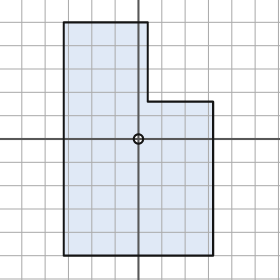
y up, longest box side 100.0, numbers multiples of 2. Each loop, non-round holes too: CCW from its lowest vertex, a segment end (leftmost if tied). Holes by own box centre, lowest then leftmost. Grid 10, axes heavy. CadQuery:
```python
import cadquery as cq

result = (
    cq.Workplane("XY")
    .moveTo(-32.0, -50.0)
    .lineTo(32.0, -50.0)
    .lineTo(32.0, 16.0)
    .lineTo(4.0, 16.0)
    .lineTo(4.0, 50.0)
    .lineTo(-32.0, 50.0)
    .close()
    .moveTo(0.0, 0.0)
    .circle(2.0)
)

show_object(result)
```